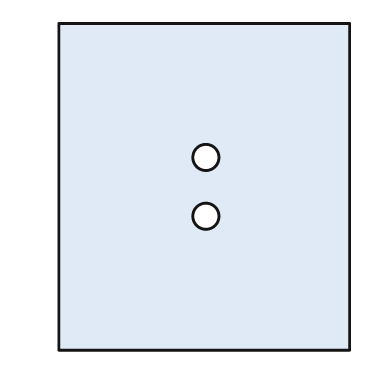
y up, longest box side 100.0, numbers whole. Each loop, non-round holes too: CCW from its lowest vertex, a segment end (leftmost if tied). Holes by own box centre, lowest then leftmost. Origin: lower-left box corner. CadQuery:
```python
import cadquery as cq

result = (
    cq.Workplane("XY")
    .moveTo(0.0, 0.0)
    .lineTo(89.0, 0.0)
    .lineTo(89.0, 100.0)
    .lineTo(0.0, 100.0)
    .close()
    .moveTo(45.0, 41.0)
    .circle(4.0)
    .moveTo(45.0, 59.0)
    .circle(4.0)
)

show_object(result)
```